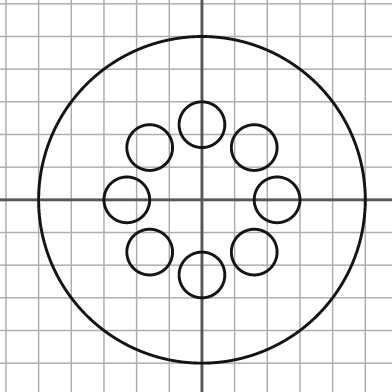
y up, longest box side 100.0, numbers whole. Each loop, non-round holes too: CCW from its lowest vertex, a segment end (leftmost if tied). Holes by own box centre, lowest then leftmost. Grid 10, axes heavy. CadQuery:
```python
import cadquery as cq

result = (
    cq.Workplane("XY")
    .moveTo(0.0, 0.0)
    .circle(50.0)
    .moveTo(0.0, -23.0)
    .circle(7.0)
    .moveTo(-16.0, -16.0)
    .circle(7.0)
    .moveTo(16.0, -16.0)
    .circle(7.0)
    .moveTo(-23.0, 0.0)
    .circle(7.0)
    .moveTo(23.0, 0.0)
    .circle(7.0)
    .moveTo(-16.0, 16.0)
    .circle(7.0)
    .moveTo(16.0, 16.0)
    .circle(7.0)
    .moveTo(0.0, 23.0)
    .circle(7.0)
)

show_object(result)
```